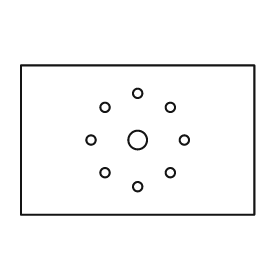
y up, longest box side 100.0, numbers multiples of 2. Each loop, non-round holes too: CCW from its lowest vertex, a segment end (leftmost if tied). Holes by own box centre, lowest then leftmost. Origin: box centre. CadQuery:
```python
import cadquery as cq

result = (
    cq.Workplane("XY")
    .moveTo(-50.0, -32.0)
    .lineTo(50.0, -32.0)
    .lineTo(50.0, 32.0)
    .lineTo(-50.0, 32.0)
    .close()
    .moveTo(0.0, -20.0)
    .circle(2.0)
    .moveTo(-14.0, -14.0)
    .circle(2.0)
    .moveTo(14.0, -14.0)
    .circle(2.0)
    .moveTo(-20.0, 0.0)
    .circle(2.0)
    .moveTo(0.0, 0.0)
    .circle(4.0)
    .moveTo(20.0, 0.0)
    .circle(2.0)
    .moveTo(-14.0, 14.0)
    .circle(2.0)
    .moveTo(14.0, 14.0)
    .circle(2.0)
    .moveTo(0.0, 20.0)
    .circle(2.0)
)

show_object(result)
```